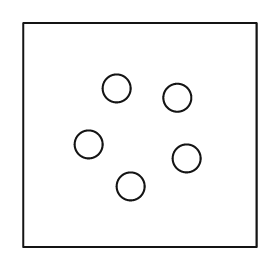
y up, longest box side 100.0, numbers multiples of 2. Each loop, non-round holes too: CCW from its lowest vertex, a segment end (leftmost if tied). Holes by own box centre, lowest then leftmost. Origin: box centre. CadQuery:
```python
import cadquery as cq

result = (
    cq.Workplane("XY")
    .moveTo(-50.0, -48.0)
    .lineTo(50.0, -48.0)
    .lineTo(50.0, 48.0)
    .lineTo(-50.0, 48.0)
    .close()
    .moveTo(-4.0, -22.0)
    .circle(6.0)
    .moveTo(20.0, -10.0)
    .circle(6.0)
    .moveTo(-22.0, -4.0)
    .circle(6.0)
    .moveTo(16.0, 16.0)
    .circle(6.0)
    .moveTo(-10.0, 20.0)
    .circle(6.0)
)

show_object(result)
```